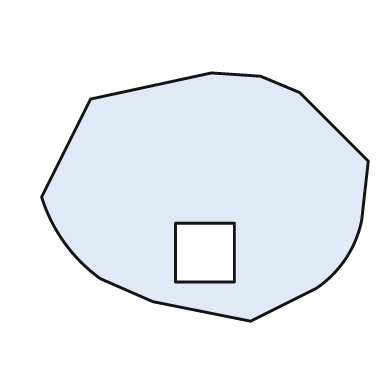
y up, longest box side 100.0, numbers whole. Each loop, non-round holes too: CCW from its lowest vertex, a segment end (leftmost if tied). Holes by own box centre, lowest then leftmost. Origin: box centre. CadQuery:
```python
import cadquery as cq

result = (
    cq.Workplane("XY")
    .moveTo(14.0, -38.0)
    .lineTo(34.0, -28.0)
    .threePointArc((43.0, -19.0), (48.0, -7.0))
    .lineTo(50.0, 11.0)
    .lineTo(29.0, 32.0)
    .lineTo(17.0, 37.0)
    .lineTo(2.0, 38.0)
    .lineTo(-35.0, 30.0)
    .lineTo(-50.0, 0.0)
    .threePointArc((-43.0, -14.0), (-32.0, -25.0))
    .lineTo(-16.0, -32.0)
    .close()
    .moveTo(-9.0, -26.0)
    .lineTo(9.0, -26.0)
    .lineTo(9.0, -8.0)
    .lineTo(-9.0, -8.0)
    .close()
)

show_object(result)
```